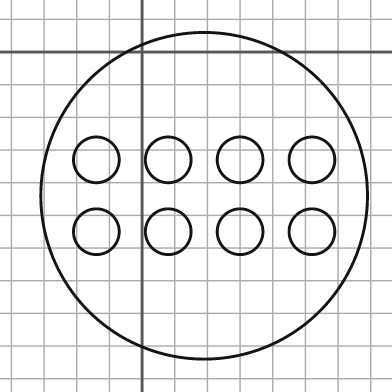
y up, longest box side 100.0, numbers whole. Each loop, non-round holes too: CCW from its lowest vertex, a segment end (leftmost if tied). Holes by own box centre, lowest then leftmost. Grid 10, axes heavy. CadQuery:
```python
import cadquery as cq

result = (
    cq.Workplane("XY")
    .moveTo(19.0, -44.0)
    .circle(50.0)
    .moveTo(-14.0, -55.0)
    .circle(7.0)
    .moveTo(8.0, -55.0)
    .circle(7.0)
    .moveTo(30.0, -55.0)
    .circle(7.0)
    .moveTo(52.0, -55.0)
    .circle(7.0)
    .moveTo(-14.0, -33.0)
    .circle(7.0)
    .moveTo(8.0, -33.0)
    .circle(7.0)
    .moveTo(30.0, -33.0)
    .circle(7.0)
    .moveTo(52.0, -33.0)
    .circle(7.0)
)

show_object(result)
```